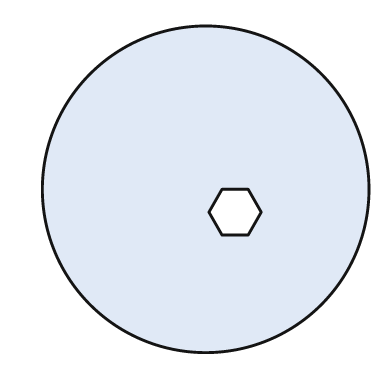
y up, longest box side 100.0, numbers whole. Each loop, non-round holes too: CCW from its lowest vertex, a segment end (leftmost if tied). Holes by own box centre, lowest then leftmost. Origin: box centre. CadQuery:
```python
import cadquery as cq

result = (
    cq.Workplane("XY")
    .moveTo(0.0, 0.0)
    .circle(50.0)
    .moveTo(5.0, -14.0)
    .lineTo(13.0, -14.0)
    .lineTo(17.0, -7.0)
    .lineTo(13.0, 0.0)
    .lineTo(5.0, 0.0)
    .lineTo(1.0, -7.0)
    .close()
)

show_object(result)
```